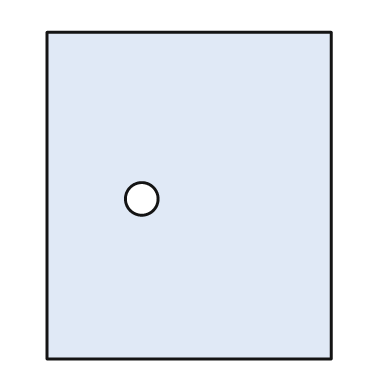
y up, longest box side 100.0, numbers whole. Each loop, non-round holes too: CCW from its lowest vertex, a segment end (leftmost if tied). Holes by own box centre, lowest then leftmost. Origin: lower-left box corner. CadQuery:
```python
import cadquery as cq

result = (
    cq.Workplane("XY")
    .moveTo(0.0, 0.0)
    .lineTo(87.0, 0.0)
    .lineTo(87.0, 100.0)
    .lineTo(0.0, 100.0)
    .close()
    .moveTo(29.0, 49.0)
    .circle(5.0)
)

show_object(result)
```